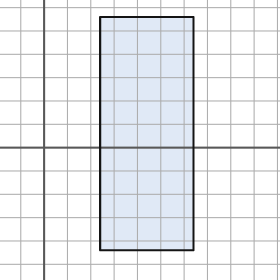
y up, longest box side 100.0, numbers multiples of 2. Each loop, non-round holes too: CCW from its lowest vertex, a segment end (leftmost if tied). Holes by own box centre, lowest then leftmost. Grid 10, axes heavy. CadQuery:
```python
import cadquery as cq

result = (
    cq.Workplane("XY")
    .moveTo(24.0, -44.0)
    .lineTo(64.0, -44.0)
    .lineTo(64.0, 56.0)
    .lineTo(24.0, 56.0)
    .close()
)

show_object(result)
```